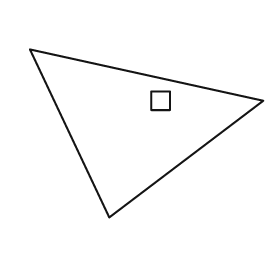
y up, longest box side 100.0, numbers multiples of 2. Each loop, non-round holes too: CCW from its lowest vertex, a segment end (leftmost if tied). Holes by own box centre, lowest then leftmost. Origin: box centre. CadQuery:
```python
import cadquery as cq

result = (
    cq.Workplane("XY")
    .moveTo(-16.0, -36.0)
    .lineTo(50.0, 14.0)
    .lineTo(-50.0, 36.0)
    .close()
    .moveTo(2.0, 10.0)
    .lineTo(10.0, 10.0)
    .lineTo(10.0, 18.0)
    .lineTo(2.0, 18.0)
    .close()
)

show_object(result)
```